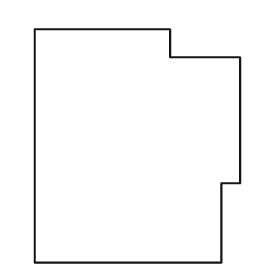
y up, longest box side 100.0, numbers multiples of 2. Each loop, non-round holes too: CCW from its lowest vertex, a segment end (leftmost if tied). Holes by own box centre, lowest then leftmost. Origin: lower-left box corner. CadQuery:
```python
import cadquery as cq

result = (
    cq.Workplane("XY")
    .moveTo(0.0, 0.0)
    .lineTo(80.0, 0.0)
    .lineTo(80.0, 34.0)
    .lineTo(88.0, 34.0)
    .lineTo(88.0, 88.0)
    .lineTo(58.0, 88.0)
    .lineTo(58.0, 100.0)
    .lineTo(0.0, 100.0)
    .close()
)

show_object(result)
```